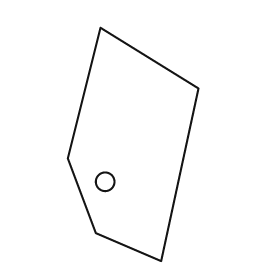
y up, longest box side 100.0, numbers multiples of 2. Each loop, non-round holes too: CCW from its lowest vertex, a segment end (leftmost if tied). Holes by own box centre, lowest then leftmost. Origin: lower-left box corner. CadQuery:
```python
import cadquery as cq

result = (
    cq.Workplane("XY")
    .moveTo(40.0, 0.0)
    .lineTo(56.0, 74.0)
    .lineTo(14.0, 100.0)
    .lineTo(0.0, 44.0)
    .lineTo(12.0, 12.0)
    .close()
    .moveTo(16.0, 34.0)
    .circle(4.0)
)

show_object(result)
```